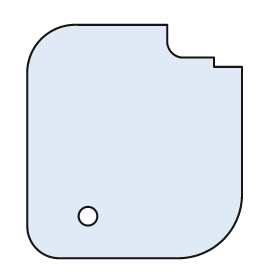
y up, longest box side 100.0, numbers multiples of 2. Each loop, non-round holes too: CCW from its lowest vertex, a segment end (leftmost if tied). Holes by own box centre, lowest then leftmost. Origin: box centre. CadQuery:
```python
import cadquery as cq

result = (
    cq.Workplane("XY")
    .moveTo(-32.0, -50.0)
    .lineTo(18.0, -50.0)
    .threePointArc((38.0, -42.0), (46.0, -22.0))
    .lineTo(46.0, 32.0)
    .lineTo(34.0, 32.0)
    .lineTo(34.0, 36.0)
    .lineTo(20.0, 36.0)
    .threePointArc((16.0, 38.0), (14.0, 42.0))
    .lineTo(14.0, 50.0)
    .lineTo(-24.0, 50.0)
    .threePointArc((-40.0, 44.0), (-46.0, 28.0))
    .lineTo(-46.0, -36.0)
    .threePointArc((-42.0, -46.0), (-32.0, -50.0))
    .close()
    .moveTo(-20.0, -32.0)
    .circle(4.0)
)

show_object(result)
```